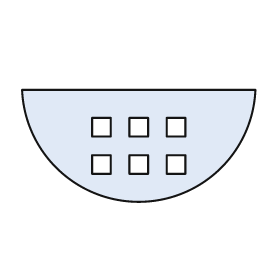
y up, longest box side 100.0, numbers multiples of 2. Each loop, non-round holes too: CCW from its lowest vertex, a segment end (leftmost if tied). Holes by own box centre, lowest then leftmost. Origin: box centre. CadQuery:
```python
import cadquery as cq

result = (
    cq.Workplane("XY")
    .moveTo(-50.0, 24.0)
    .threePointArc((0.0, -24.0), (50.0, 24.0))
    .close()
    .moveTo(-20.0, -12.0)
    .lineTo(-12.0, -12.0)
    .lineTo(-12.0, -4.0)
    .lineTo(-20.0, -4.0)
    .close()
    .moveTo(-4.0, -12.0)
    .lineTo(4.0, -12.0)
    .lineTo(4.0, -4.0)
    .lineTo(-4.0, -4.0)
    .close()
    .moveTo(12.0, -12.0)
    .lineTo(20.0, -12.0)
    .lineTo(20.0, -4.0)
    .lineTo(12.0, -4.0)
    .close()
    .moveTo(-20.0, 4.0)
    .lineTo(-12.0, 4.0)
    .lineTo(-12.0, 12.0)
    .lineTo(-20.0, 12.0)
    .close()
    .moveTo(-4.0, 4.0)
    .lineTo(4.0, 4.0)
    .lineTo(4.0, 12.0)
    .lineTo(-4.0, 12.0)
    .close()
    .moveTo(12.0, 4.0)
    .lineTo(20.0, 4.0)
    .lineTo(20.0, 12.0)
    .lineTo(12.0, 12.0)
    .close()
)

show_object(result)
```